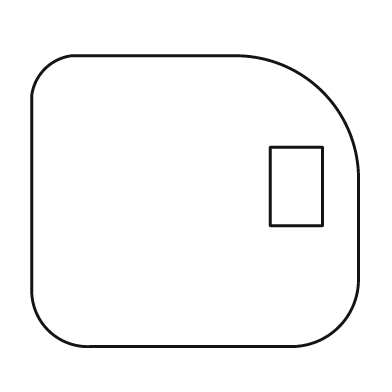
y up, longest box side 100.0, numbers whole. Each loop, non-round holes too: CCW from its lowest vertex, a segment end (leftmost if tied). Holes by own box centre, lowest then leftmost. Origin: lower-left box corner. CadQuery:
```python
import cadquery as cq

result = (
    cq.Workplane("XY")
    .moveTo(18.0, 0.0)
    .lineTo(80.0, 0.0)
    .threePointArc((94.0, 6.0), (100.0, 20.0))
    .lineTo(100.0, 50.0)
    .threePointArc((89.0, 78.0), (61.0, 89.0))
    .lineTo(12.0, 89.0)
    .threePointArc((4.0, 85.0), (0.0, 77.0))
    .lineTo(0.0, 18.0)
    .threePointArc((5.0, 5.0), (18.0, 0.0))
    .close()
    .moveTo(73.0, 37.0)
    .lineTo(89.0, 37.0)
    .lineTo(89.0, 61.0)
    .lineTo(73.0, 61.0)
    .close()
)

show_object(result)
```